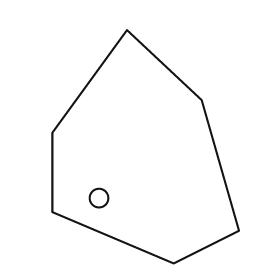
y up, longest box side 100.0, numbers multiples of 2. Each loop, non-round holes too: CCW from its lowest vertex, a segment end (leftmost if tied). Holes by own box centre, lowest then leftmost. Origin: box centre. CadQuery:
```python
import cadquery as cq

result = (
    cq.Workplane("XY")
    .moveTo(12.0, -50.0)
    .lineTo(40.0, -36.0)
    .lineTo(24.0, 20.0)
    .lineTo(-8.0, 50.0)
    .lineTo(-40.0, 6.0)
    .lineTo(-40.0, -28.0)
    .close()
    .moveTo(-20.0, -22.0)
    .circle(4.0)
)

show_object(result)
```